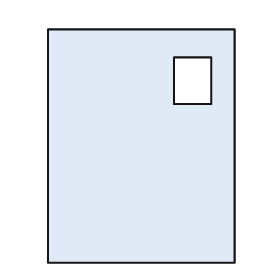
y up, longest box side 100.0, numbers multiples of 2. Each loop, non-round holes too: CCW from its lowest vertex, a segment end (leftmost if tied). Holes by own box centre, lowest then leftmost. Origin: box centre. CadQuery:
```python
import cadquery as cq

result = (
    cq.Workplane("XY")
    .moveTo(-40.0, -50.0)
    .lineTo(40.0, -50.0)
    .lineTo(40.0, 50.0)
    .lineTo(-40.0, 50.0)
    .close()
    .moveTo(14.0, 18.0)
    .lineTo(30.0, 18.0)
    .lineTo(30.0, 38.0)
    .lineTo(14.0, 38.0)
    .close()
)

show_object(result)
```